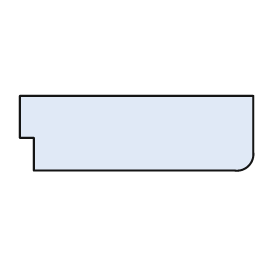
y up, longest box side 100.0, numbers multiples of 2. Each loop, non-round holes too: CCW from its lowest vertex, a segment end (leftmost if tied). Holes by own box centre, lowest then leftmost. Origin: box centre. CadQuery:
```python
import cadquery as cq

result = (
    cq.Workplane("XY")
    .moveTo(-44.0, -16.0)
    .lineTo(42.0, -16.0)
    .threePointArc((48.0, -14.0), (50.0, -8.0))
    .lineTo(50.0, 16.0)
    .lineTo(-50.0, 16.0)
    .lineTo(-50.0, -2.0)
    .lineTo(-44.0, -2.0)
    .close()
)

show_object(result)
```